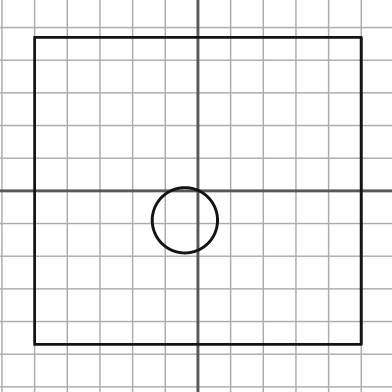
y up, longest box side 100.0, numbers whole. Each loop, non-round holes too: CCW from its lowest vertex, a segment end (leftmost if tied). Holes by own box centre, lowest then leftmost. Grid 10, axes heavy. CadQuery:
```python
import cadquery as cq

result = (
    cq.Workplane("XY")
    .moveTo(-50.0, -47.0)
    .lineTo(50.0, -47.0)
    .lineTo(50.0, 47.0)
    .lineTo(-50.0, 47.0)
    .close()
    .moveTo(-4.0, -9.0)
    .circle(10.0)
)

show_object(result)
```